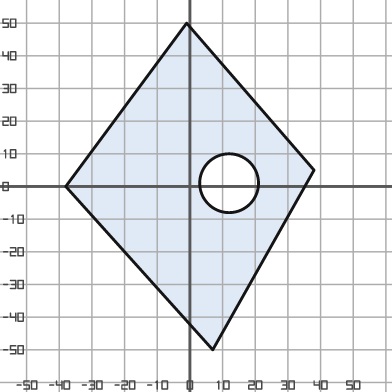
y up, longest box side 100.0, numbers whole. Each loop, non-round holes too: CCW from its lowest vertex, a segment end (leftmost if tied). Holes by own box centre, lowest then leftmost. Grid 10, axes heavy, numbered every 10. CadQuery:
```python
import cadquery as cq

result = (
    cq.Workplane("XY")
    .moveTo(7.0, -50.0)
    .lineTo(38.0, 5.0)
    .lineTo(-1.0, 50.0)
    .lineTo(-38.0, 0.0)
    .close()
    .moveTo(12.0, 1.0)
    .circle(9.0)
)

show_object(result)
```